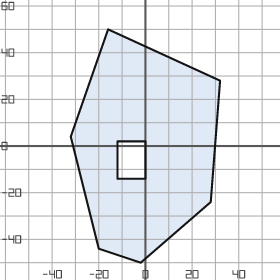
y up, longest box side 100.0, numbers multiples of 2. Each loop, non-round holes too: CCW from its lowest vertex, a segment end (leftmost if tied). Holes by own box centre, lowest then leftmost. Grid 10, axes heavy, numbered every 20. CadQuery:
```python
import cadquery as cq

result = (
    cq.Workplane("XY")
    .moveTo(-2.0, -50.0)
    .lineTo(28.0, -24.0)
    .lineTo(32.0, 28.0)
    .lineTo(-16.0, 50.0)
    .lineTo(-32.0, 4.0)
    .lineTo(-20.0, -44.0)
    .close()
    .moveTo(-12.0, -14.0)
    .lineTo(0.0, -14.0)
    .lineTo(0.0, 2.0)
    .lineTo(-12.0, 2.0)
    .close()
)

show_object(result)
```